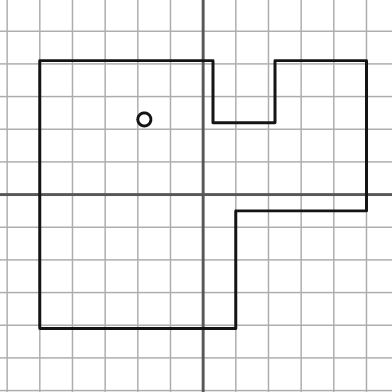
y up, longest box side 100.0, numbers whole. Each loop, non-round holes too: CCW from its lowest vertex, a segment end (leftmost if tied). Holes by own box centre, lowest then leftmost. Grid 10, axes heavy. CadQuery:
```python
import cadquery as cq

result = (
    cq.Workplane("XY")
    .moveTo(-50.0, -41.0)
    .lineTo(10.0, -41.0)
    .lineTo(10.0, -5.0)
    .lineTo(50.0, -5.0)
    .lineTo(50.0, 41.0)
    .lineTo(22.0, 41.0)
    .lineTo(22.0, 22.0)
    .lineTo(3.0, 22.0)
    .lineTo(3.0, 41.0)
    .lineTo(-50.0, 41.0)
    .close()
    .moveTo(-18.0, 23.0)
    .circle(2.0)
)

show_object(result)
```